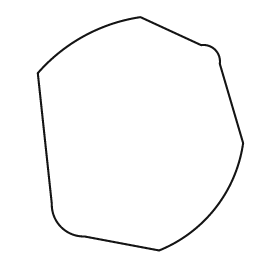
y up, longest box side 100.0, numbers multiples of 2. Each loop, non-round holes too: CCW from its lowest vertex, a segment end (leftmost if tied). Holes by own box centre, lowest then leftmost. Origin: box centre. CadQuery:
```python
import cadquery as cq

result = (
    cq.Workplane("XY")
    .moveTo(8.0, -50.0)
    .threePointArc((32.0, -32.0), (44.0, -4.0))
    .lineTo(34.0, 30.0)
    .threePointArc((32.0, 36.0), (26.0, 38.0))
    .lineTo(0.0, 50.0)
    .threePointArc((-24.0, 42.0), (-44.0, 26.0))
    .lineTo(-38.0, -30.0)
    .threePointArc((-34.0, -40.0), (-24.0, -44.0))
    .close()
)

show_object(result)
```